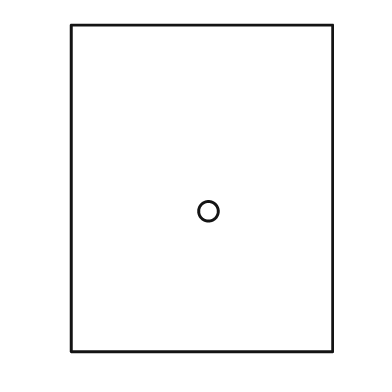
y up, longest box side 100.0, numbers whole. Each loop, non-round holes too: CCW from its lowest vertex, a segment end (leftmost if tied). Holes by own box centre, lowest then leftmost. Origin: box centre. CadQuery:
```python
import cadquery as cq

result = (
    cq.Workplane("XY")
    .moveTo(-40.0, -50.0)
    .lineTo(40.0, -50.0)
    .lineTo(40.0, 50.0)
    .lineTo(-40.0, 50.0)
    .close()
    .moveTo(2.0, -7.0)
    .circle(3.0)
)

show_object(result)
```